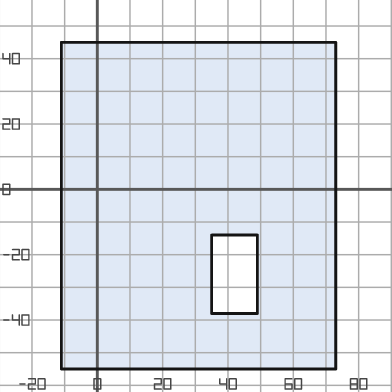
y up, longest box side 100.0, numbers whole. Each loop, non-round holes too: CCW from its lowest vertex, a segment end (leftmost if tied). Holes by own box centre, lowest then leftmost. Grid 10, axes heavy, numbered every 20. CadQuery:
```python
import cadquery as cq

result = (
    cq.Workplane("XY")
    .moveTo(-11.0, -55.0)
    .lineTo(73.0, -55.0)
    .lineTo(73.0, 45.0)
    .lineTo(-11.0, 45.0)
    .close()
    .moveTo(35.0, -38.0)
    .lineTo(49.0, -38.0)
    .lineTo(49.0, -14.0)
    .lineTo(35.0, -14.0)
    .close()
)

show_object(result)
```